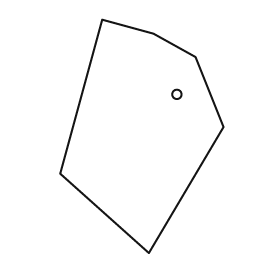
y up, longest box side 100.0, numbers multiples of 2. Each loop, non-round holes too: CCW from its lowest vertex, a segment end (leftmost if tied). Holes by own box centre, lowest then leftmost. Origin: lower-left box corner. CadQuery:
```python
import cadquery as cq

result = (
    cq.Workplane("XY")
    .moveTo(38.0, 0.0)
    .lineTo(70.0, 54.0)
    .lineTo(58.0, 84.0)
    .lineTo(40.0, 94.0)
    .lineTo(18.0, 100.0)
    .lineTo(0.0, 34.0)
    .close()
    .moveTo(50.0, 68.0)
    .circle(2.0)
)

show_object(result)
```